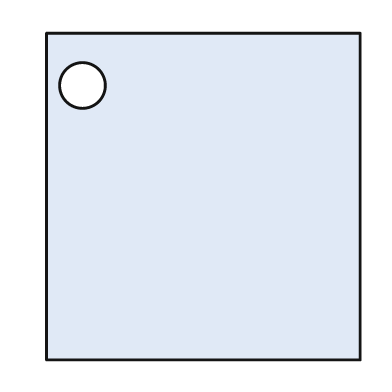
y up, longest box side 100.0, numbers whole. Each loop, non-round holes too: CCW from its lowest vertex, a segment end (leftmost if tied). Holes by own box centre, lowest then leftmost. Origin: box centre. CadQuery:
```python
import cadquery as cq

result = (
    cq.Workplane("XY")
    .moveTo(-48.0, -50.0)
    .lineTo(48.0, -50.0)
    .lineTo(48.0, 50.0)
    .lineTo(-48.0, 50.0)
    .close()
    .moveTo(-37.0, 34.0)
    .circle(7.0)
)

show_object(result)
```